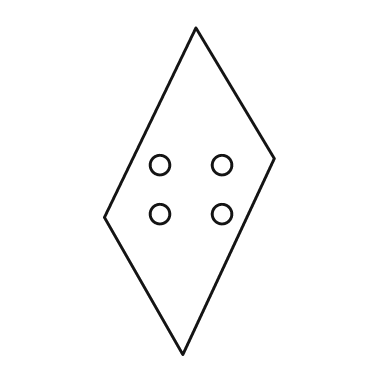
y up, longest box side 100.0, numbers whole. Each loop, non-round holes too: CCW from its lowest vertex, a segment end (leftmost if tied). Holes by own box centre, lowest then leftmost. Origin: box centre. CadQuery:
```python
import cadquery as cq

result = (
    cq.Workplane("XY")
    .moveTo(-2.0, -50.0)
    .lineTo(26.0, 10.0)
    .lineTo(2.0, 50.0)
    .lineTo(-26.0, -8.0)
    .close()
    .moveTo(-9.0, -7.0)
    .circle(3.0)
    .moveTo(10.0, -7.0)
    .circle(3.0)
    .moveTo(-9.0, 8.0)
    .circle(3.0)
    .moveTo(10.0, 8.0)
    .circle(3.0)
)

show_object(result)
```